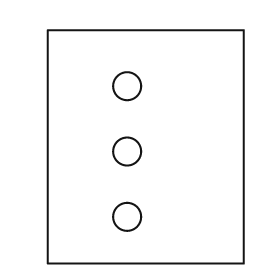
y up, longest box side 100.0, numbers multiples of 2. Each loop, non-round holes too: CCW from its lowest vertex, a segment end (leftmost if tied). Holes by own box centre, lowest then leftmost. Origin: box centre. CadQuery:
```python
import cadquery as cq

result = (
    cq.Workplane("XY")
    .moveTo(-42.0, -50.0)
    .lineTo(42.0, -50.0)
    .lineTo(42.0, 50.0)
    .lineTo(-42.0, 50.0)
    .close()
    .moveTo(-8.0, -30.0)
    .circle(6.0)
    .moveTo(-8.0, -2.0)
    .circle(6.0)
    .moveTo(-8.0, 26.0)
    .circle(6.0)
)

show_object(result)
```